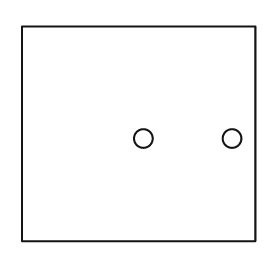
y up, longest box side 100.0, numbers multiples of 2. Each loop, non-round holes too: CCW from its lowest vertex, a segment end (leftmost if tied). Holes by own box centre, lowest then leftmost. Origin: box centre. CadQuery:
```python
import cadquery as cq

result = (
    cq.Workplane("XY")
    .moveTo(-50.0, -46.0)
    .lineTo(50.0, -46.0)
    .lineTo(50.0, 46.0)
    .lineTo(-50.0, 46.0)
    .close()
    .moveTo(2.0, -2.0)
    .circle(4.0)
    .moveTo(40.0, -2.0)
    .circle(4.0)
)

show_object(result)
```